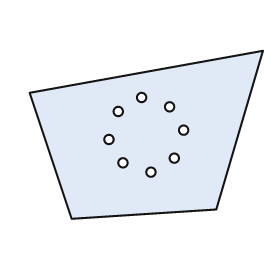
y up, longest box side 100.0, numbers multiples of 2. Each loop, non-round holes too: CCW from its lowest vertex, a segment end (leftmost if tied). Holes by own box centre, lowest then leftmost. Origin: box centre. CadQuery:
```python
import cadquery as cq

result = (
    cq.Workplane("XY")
    .moveTo(-32.0, -36.0)
    .lineTo(30.0, -32.0)
    .lineTo(50.0, 36.0)
    .lineTo(-50.0, 18.0)
    .close()
    .moveTo(2.0, -16.0)
    .circle(2.0)
    .moveTo(-10.0, -12.0)
    .circle(2.0)
    .moveTo(12.0, -10.0)
    .circle(2.0)
    .moveTo(-16.0, -2.0)
    .circle(2.0)
    .moveTo(16.0, 2.0)
    .circle(2.0)
    .moveTo(-12.0, 10.0)
    .circle(2.0)
    .moveTo(10.0, 12.0)
    .circle(2.0)
    .moveTo(-2.0, 16.0)
    .circle(2.0)
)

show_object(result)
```